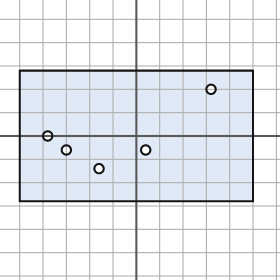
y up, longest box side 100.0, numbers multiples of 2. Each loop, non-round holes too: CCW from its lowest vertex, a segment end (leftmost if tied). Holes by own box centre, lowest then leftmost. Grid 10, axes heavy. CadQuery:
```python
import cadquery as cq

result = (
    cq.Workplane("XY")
    .moveTo(-50.0, -28.0)
    .lineTo(50.0, -28.0)
    .lineTo(50.0, 28.0)
    .lineTo(-50.0, 28.0)
    .close()
    .moveTo(-16.0, -14.0)
    .circle(2.0)
    .moveTo(-30.0, -6.0)
    .circle(2.0)
    .moveTo(4.0, -6.0)
    .circle(2.0)
    .moveTo(-38.0, 0.0)
    .circle(2.0)
    .moveTo(32.0, 20.0)
    .circle(2.0)
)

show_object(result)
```